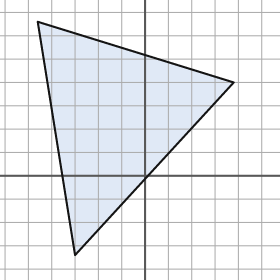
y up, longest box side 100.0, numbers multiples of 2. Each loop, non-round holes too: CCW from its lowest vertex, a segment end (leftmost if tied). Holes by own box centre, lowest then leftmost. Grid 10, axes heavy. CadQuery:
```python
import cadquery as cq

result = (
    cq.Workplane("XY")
    .moveTo(-30.0, -34.0)
    .lineTo(38.0, 40.0)
    .lineTo(-46.0, 66.0)
    .close()
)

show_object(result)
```